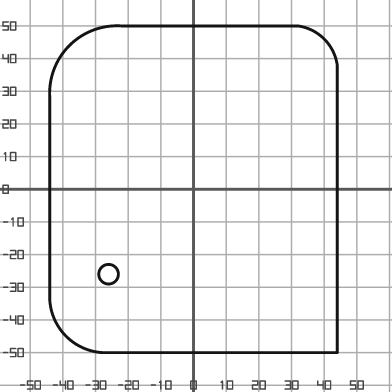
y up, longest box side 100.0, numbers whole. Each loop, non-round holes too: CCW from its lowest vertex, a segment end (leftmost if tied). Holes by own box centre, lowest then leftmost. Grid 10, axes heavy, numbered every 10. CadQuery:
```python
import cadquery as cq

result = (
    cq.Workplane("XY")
    .moveTo(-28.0, -50.0)
    .lineTo(44.0, -50.0)
    .lineTo(44.0, 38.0)
    .threePointArc((40.0, 46.0), (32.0, 50.0))
    .lineTo(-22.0, 50.0)
    .threePointArc((-38.0, 44.0), (-44.0, 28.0))
    .lineTo(-44.0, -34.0)
    .threePointArc((-39.0, -45.0), (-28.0, -50.0))
    .close()
    .moveTo(-26.0, -26.0)
    .circle(3.0)
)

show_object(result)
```